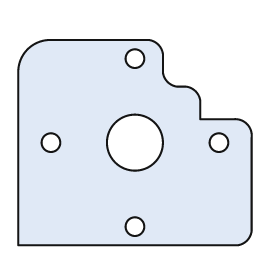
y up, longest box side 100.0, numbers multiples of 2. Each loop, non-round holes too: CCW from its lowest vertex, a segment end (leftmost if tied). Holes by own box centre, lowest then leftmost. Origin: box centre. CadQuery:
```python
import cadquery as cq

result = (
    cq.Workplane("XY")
    .moveTo(-50.0, -44.0)
    .lineTo(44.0, -44.0)
    .threePointArc((48.0, -42.0), (50.0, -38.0))
    .lineTo(50.0, 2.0)
    .threePointArc((48.0, 8.0), (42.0, 10.0))
    .lineTo(28.0, 10.0)
    .lineTo(28.0, 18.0)
    .threePointArc((26.0, 22.0), (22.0, 24.0))
    .lineTo(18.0, 24.0)
    .threePointArc((14.0, 26.0), (12.0, 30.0))
    .lineTo(12.0, 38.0)
    .threePointArc((10.0, 42.0), (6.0, 44.0))
    .lineTo(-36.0, 44.0)
    .threePointArc((-46.0, 40.0), (-50.0, 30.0))
    .close()
    .moveTo(0.0, -36.0)
    .circle(4.0)
    .moveTo(-36.0, 0.0)
    .circle(4.0)
    .moveTo(0.0, 0.0)
    .circle(12.0)
    .moveTo(36.0, 0.0)
    .circle(4.0)
    .moveTo(0.0, 36.0)
    .circle(4.0)
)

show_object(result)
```